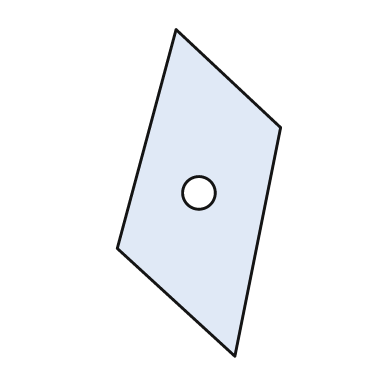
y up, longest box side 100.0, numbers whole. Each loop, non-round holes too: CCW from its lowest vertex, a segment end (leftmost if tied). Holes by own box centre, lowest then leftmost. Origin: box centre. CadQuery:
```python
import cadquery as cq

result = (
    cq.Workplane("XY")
    .moveTo(11.0, -50.0)
    .lineTo(25.0, 20.0)
    .lineTo(-7.0, 50.0)
    .lineTo(-25.0, -17.0)
    .close()
    .moveTo(0.0, 0.0)
    .circle(5.0)
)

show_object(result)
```